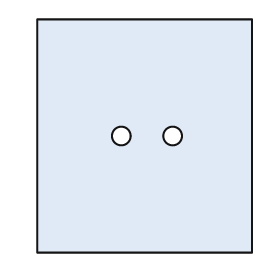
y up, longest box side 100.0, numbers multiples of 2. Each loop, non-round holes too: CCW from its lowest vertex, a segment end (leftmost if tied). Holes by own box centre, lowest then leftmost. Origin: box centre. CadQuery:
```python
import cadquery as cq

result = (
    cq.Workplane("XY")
    .moveTo(-46.0, -50.0)
    .lineTo(46.0, -50.0)
    .lineTo(46.0, 50.0)
    .lineTo(-46.0, 50.0)
    .close()
    .moveTo(-10.0, 0.0)
    .circle(4.0)
    .moveTo(12.0, 0.0)
    .circle(4.0)
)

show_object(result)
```